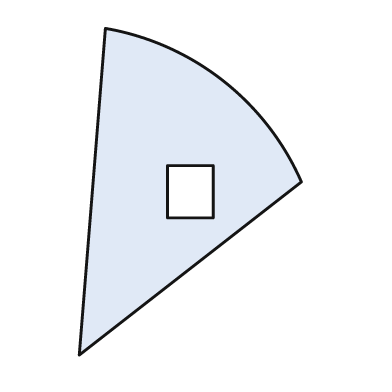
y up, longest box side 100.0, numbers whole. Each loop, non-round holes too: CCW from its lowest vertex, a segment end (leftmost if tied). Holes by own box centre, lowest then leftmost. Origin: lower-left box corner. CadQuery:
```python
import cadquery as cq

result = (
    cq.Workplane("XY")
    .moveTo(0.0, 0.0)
    .lineTo(68.0, 53.0)
    .threePointArc((44.0, 84.0), (8.0, 100.0))
    .close()
    .moveTo(27.0, 42.0)
    .lineTo(41.0, 42.0)
    .lineTo(41.0, 58.0)
    .lineTo(27.0, 58.0)
    .close()
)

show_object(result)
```